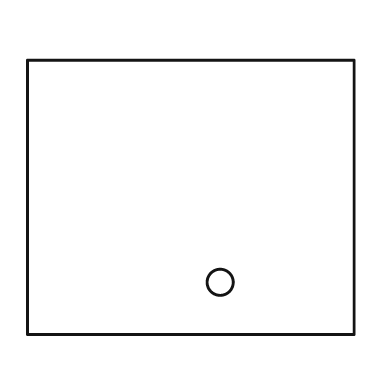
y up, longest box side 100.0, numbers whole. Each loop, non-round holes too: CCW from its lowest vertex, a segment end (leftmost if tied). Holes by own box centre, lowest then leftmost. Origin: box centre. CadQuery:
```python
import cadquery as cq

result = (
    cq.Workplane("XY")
    .moveTo(-50.0, -42.0)
    .lineTo(50.0, -42.0)
    .lineTo(50.0, 42.0)
    .lineTo(-50.0, 42.0)
    .close()
    .moveTo(9.0, -26.0)
    .circle(4.0)
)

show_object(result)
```